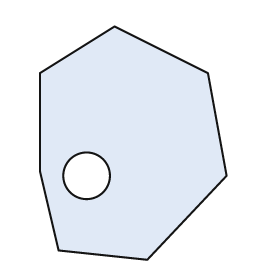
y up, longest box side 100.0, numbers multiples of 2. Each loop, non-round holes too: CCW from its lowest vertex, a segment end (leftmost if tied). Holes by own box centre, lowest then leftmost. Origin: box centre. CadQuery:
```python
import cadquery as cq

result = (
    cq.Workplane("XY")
    .moveTo(6.0, -50.0)
    .lineTo(40.0, -14.0)
    .lineTo(32.0, 30.0)
    .lineTo(-8.0, 50.0)
    .lineTo(-40.0, 30.0)
    .lineTo(-40.0, -12.0)
    .lineTo(-32.0, -46.0)
    .close()
    .moveTo(-20.0, -14.0)
    .circle(10.0)
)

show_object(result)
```